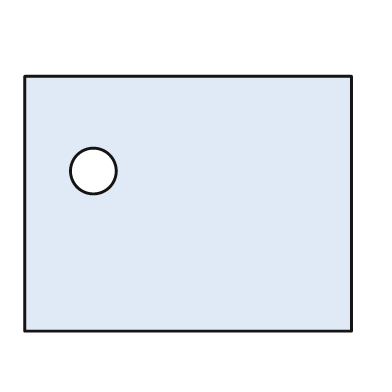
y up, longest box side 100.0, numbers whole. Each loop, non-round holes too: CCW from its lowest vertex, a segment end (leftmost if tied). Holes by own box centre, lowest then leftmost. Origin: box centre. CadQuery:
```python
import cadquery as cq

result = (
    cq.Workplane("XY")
    .moveTo(-50.0, -39.0)
    .lineTo(50.0, -39.0)
    .lineTo(50.0, 39.0)
    .lineTo(-50.0, 39.0)
    .close()
    .moveTo(-29.0, 10.0)
    .circle(7.0)
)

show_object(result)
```